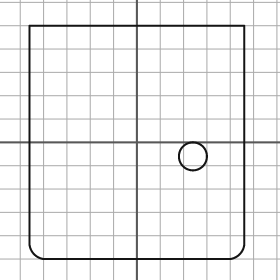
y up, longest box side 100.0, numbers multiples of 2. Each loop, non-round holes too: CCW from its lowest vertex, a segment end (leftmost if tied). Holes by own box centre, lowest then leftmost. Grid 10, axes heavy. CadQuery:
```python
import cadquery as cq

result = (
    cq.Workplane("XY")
    .moveTo(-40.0, -50.0)
    .lineTo(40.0, -50.0)
    .threePointArc((44.0, -48.0), (46.0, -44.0))
    .lineTo(46.0, 50.0)
    .lineTo(-46.0, 50.0)
    .lineTo(-46.0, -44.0)
    .threePointArc((-44.0, -48.0), (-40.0, -50.0))
    .close()
    .moveTo(24.0, -6.0)
    .circle(6.0)
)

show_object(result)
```